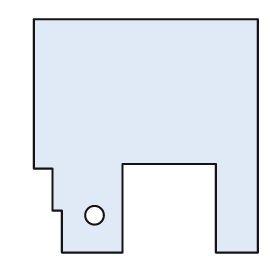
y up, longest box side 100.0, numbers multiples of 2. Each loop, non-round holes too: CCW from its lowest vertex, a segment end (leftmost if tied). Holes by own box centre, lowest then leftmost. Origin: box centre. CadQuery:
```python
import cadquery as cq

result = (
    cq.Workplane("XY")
    .moveTo(-36.0, -50.0)
    .lineTo(-10.0, -50.0)
    .lineTo(-10.0, -12.0)
    .lineTo(30.0, -12.0)
    .lineTo(30.0, -50.0)
    .lineTo(48.0, -50.0)
    .lineTo(48.0, 50.0)
    .lineTo(-48.0, 50.0)
    .lineTo(-48.0, -14.0)
    .lineTo(-40.0, -14.0)
    .lineTo(-40.0, -32.0)
    .lineTo(-36.0, -32.0)
    .close()
    .moveTo(-22.0, -34.0)
    .circle(4.0)
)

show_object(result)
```